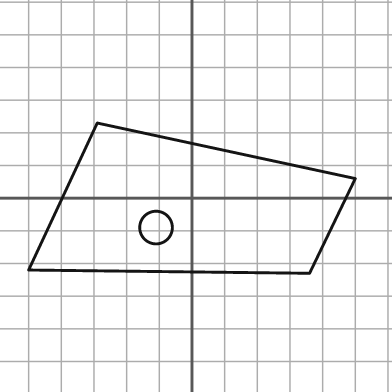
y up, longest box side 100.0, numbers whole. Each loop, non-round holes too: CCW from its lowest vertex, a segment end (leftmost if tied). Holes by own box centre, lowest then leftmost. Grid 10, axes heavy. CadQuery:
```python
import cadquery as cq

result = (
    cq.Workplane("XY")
    .moveTo(36.0, -23.0)
    .lineTo(50.0, 6.0)
    .lineTo(-29.0, 23.0)
    .lineTo(-50.0, -22.0)
    .close()
    .moveTo(-11.0, -9.0)
    .circle(5.0)
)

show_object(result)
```